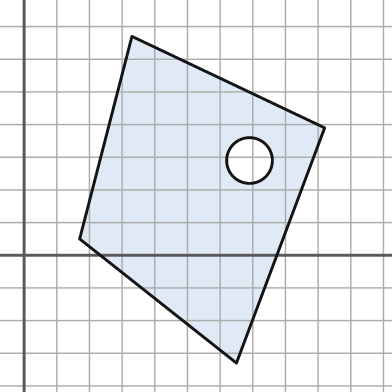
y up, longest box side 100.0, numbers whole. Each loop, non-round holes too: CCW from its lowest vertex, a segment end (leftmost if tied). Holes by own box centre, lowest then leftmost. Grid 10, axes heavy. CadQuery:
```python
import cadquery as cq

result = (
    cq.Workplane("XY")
    .moveTo(65.0, -33.0)
    .lineTo(92.0, 39.0)
    .lineTo(33.0, 67.0)
    .lineTo(17.0, 5.0)
    .close()
    .moveTo(69.0, 29.0)
    .circle(7.0)
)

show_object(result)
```